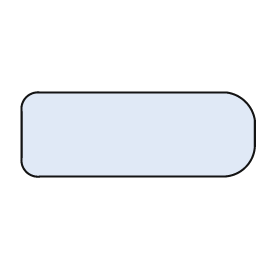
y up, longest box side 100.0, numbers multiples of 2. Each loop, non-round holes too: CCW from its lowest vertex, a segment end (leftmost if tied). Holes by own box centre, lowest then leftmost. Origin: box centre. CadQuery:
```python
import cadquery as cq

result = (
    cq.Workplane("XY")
    .moveTo(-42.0, -18.0)
    .lineTo(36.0, -18.0)
    .threePointArc((46.0, -14.0), (50.0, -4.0))
    .lineTo(50.0, 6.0)
    .threePointArc((46.0, 14.0), (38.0, 18.0))
    .lineTo(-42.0, 18.0)
    .threePointArc((-48.0, 16.0), (-50.0, 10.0))
    .lineTo(-50.0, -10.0)
    .threePointArc((-48.0, -16.0), (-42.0, -18.0))
    .close()
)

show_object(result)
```